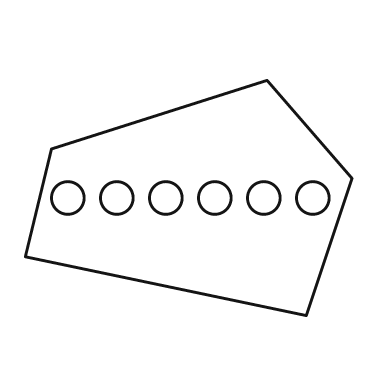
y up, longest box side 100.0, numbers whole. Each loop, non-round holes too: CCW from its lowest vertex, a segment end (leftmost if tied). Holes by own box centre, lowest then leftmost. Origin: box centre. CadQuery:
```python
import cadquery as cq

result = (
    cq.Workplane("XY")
    .moveTo(36.0, -36.0)
    .lineTo(50.0, 6.0)
    .lineTo(24.0, 36.0)
    .lineTo(-42.0, 15.0)
    .lineTo(-50.0, -18.0)
    .close()
    .moveTo(-37.0, 0.0)
    .circle(5.0)
    .moveTo(-22.0, 0.0)
    .circle(5.0)
    .moveTo(-7.0, 0.0)
    .circle(5.0)
    .moveTo(8.0, 0.0)
    .circle(5.0)
    .moveTo(23.0, 0.0)
    .circle(5.0)
    .moveTo(38.0, 0.0)
    .circle(5.0)
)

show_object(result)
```